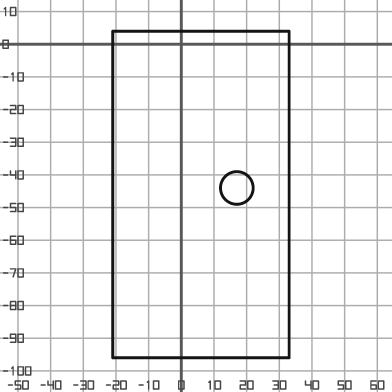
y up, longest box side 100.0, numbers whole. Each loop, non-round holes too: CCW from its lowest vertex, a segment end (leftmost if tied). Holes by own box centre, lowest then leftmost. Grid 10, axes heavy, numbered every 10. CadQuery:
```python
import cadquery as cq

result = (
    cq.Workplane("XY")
    .moveTo(-21.0, -96.0)
    .lineTo(33.0, -96.0)
    .lineTo(33.0, 4.0)
    .lineTo(-21.0, 4.0)
    .close()
    .moveTo(17.0, -44.0)
    .circle(5.0)
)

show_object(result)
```